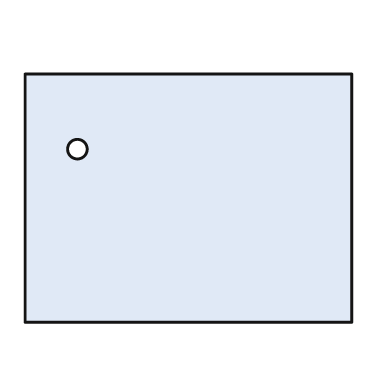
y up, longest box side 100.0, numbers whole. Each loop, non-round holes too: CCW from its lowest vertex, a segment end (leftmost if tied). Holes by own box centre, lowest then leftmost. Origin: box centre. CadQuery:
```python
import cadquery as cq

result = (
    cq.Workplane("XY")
    .moveTo(-50.0, -38.0)
    .lineTo(50.0, -38.0)
    .lineTo(50.0, 38.0)
    .lineTo(-50.0, 38.0)
    .close()
    .moveTo(-34.0, 15.0)
    .circle(3.0)
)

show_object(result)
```